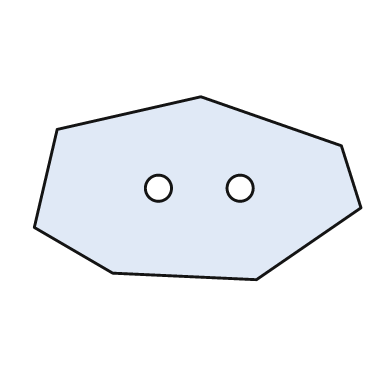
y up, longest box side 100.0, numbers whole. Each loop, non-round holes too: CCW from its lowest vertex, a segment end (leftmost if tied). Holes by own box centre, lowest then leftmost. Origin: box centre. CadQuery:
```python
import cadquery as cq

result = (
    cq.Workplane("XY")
    .moveTo(18.0, -28.0)
    .lineTo(50.0, -6.0)
    .lineTo(44.0, 13.0)
    .lineTo(1.0, 28.0)
    .lineTo(-43.0, 18.0)
    .lineTo(-50.0, -12.0)
    .lineTo(-26.0, -26.0)
    .close()
    .moveTo(-12.0, 0.0)
    .circle(4.0)
    .moveTo(13.0, 0.0)
    .circle(4.0)
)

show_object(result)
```